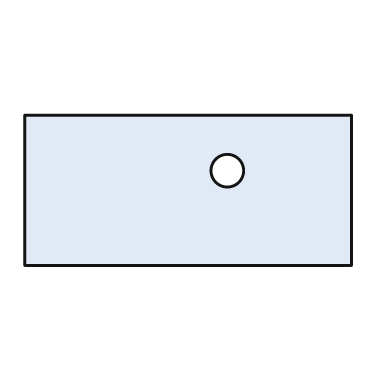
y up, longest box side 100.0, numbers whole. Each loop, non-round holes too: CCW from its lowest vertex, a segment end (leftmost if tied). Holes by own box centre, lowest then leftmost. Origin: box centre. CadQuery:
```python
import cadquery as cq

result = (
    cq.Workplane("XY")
    .moveTo(-50.0, -23.0)
    .lineTo(50.0, -23.0)
    .lineTo(50.0, 23.0)
    .lineTo(-50.0, 23.0)
    .close()
    .moveTo(12.0, 6.0)
    .circle(5.0)
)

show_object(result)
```